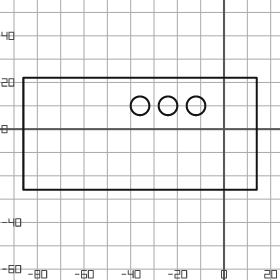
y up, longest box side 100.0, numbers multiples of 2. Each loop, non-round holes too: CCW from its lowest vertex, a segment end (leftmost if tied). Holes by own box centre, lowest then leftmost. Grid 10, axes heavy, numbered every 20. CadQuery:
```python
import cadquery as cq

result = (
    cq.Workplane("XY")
    .moveTo(-86.0, -26.0)
    .lineTo(14.0, -26.0)
    .lineTo(14.0, 22.0)
    .lineTo(-86.0, 22.0)
    .close()
    .moveTo(-36.0, 10.0)
    .circle(4.0)
    .moveTo(-24.0, 10.0)
    .circle(4.0)
    .moveTo(-12.0, 10.0)
    .circle(4.0)
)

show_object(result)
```